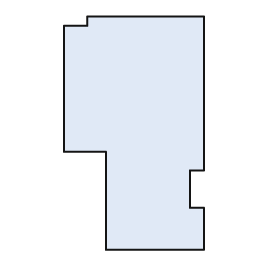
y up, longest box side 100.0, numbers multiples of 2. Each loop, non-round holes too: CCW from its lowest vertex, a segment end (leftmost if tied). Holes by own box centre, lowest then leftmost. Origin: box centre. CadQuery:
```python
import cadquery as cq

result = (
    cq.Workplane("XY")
    .moveTo(-12.0, -50.0)
    .lineTo(30.0, -50.0)
    .lineTo(30.0, -32.0)
    .lineTo(24.0, -32.0)
    .lineTo(24.0, -16.0)
    .lineTo(30.0, -16.0)
    .lineTo(30.0, 50.0)
    .lineTo(-20.0, 50.0)
    .lineTo(-20.0, 46.0)
    .lineTo(-30.0, 46.0)
    .lineTo(-30.0, -8.0)
    .lineTo(-12.0, -8.0)
    .close()
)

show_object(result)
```